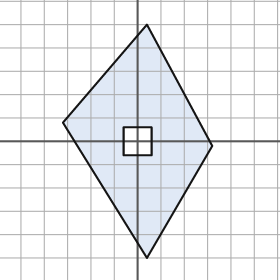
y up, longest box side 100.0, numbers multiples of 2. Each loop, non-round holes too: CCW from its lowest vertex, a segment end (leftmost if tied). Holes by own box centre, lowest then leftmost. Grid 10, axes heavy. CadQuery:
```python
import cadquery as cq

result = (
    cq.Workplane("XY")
    .moveTo(4.0, -50.0)
    .lineTo(32.0, -2.0)
    .lineTo(4.0, 50.0)
    .lineTo(-32.0, 8.0)
    .close()
    .moveTo(-6.0, -6.0)
    .lineTo(6.0, -6.0)
    .lineTo(6.0, 6.0)
    .lineTo(-6.0, 6.0)
    .close()
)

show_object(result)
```